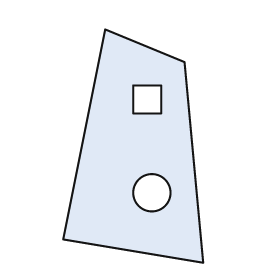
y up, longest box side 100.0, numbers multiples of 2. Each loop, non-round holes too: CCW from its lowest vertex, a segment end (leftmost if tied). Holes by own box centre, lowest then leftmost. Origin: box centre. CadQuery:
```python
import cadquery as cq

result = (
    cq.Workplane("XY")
    .moveTo(30.0, -50.0)
    .lineTo(22.0, 36.0)
    .lineTo(-12.0, 50.0)
    .lineTo(-30.0, -40.0)
    .close()
    .moveTo(8.0, -20.0)
    .circle(8.0)
    .moveTo(0.0, 14.0)
    .lineTo(12.0, 14.0)
    .lineTo(12.0, 26.0)
    .lineTo(0.0, 26.0)
    .close()
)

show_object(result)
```